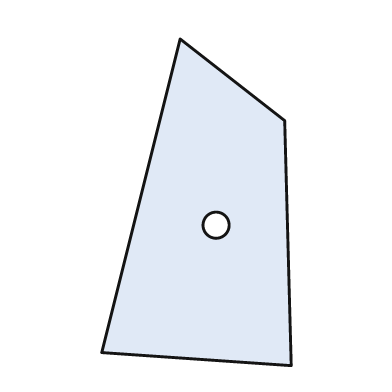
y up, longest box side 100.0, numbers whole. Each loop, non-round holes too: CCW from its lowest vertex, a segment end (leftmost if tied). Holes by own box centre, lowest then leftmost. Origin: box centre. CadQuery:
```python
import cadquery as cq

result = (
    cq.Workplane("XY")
    .moveTo(29.0, -50.0)
    .lineTo(27.0, 25.0)
    .lineTo(-5.0, 50.0)
    .lineTo(-29.0, -46.0)
    .close()
    .moveTo(6.0, -7.0)
    .circle(4.0)
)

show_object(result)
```